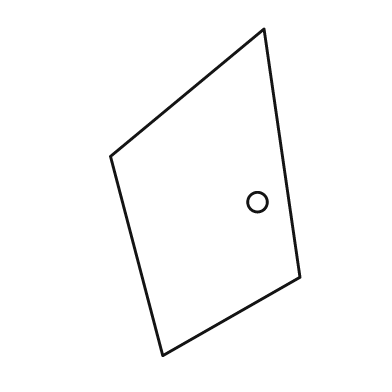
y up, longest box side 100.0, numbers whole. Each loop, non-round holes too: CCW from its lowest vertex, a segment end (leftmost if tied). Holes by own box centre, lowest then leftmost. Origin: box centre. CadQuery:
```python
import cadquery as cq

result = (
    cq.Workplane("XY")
    .moveTo(-13.0, -50.0)
    .lineTo(29.0, -26.0)
    .lineTo(18.0, 50.0)
    .lineTo(-29.0, 11.0)
    .close()
    .moveTo(16.0, -3.0)
    .circle(3.0)
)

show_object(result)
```